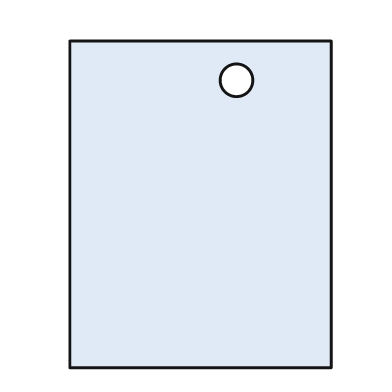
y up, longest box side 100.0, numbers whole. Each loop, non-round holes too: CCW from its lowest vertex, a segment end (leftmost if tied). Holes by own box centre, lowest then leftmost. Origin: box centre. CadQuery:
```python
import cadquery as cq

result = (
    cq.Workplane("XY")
    .moveTo(-40.0, -50.0)
    .lineTo(40.0, -50.0)
    .lineTo(40.0, 50.0)
    .lineTo(-40.0, 50.0)
    .close()
    .moveTo(11.0, 38.0)
    .circle(5.0)
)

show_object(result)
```